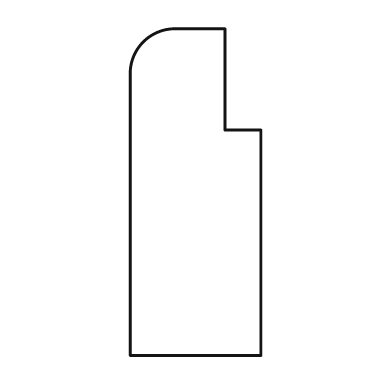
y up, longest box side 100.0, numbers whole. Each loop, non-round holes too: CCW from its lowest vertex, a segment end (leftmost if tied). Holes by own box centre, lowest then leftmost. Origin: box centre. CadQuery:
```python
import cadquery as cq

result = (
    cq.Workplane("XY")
    .moveTo(-20.0, -50.0)
    .lineTo(20.0, -50.0)
    .lineTo(20.0, 19.0)
    .lineTo(9.0, 19.0)
    .lineTo(9.0, 50.0)
    .lineTo(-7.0, 50.0)
    .threePointArc((-16.0, 46.0), (-20.0, 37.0))
    .close()
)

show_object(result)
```